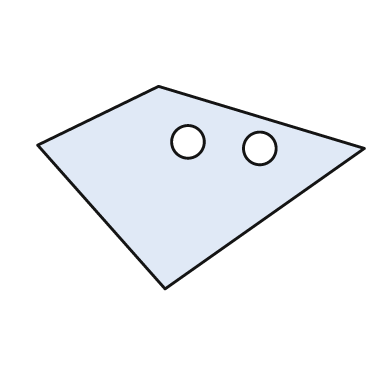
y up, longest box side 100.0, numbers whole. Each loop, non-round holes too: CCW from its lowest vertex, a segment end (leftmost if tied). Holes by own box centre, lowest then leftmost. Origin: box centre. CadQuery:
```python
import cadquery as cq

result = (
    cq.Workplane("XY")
    .moveTo(-11.0, -31.0)
    .lineTo(50.0, 12.0)
    .lineTo(-13.0, 31.0)
    .lineTo(-50.0, 13.0)
    .close()
    .moveTo(18.0, 12.0)
    .circle(5.0)
    .moveTo(-4.0, 14.0)
    .circle(5.0)
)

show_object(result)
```